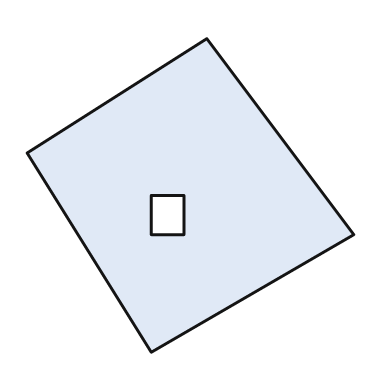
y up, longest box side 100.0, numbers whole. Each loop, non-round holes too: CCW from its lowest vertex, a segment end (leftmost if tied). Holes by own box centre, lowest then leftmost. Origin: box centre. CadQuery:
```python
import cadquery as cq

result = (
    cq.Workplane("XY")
    .moveTo(-12.0, -48.0)
    .lineTo(50.0, -12.0)
    .lineTo(5.0, 48.0)
    .lineTo(-50.0, 13.0)
    .close()
    .moveTo(-12.0, -12.0)
    .lineTo(-2.0, -12.0)
    .lineTo(-2.0, 0.0)
    .lineTo(-12.0, 0.0)
    .close()
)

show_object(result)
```